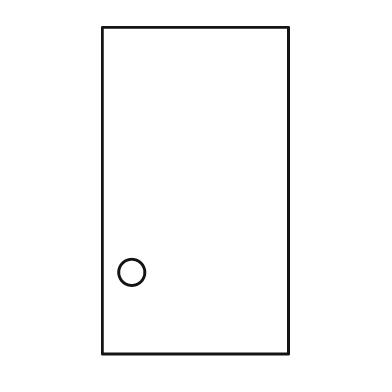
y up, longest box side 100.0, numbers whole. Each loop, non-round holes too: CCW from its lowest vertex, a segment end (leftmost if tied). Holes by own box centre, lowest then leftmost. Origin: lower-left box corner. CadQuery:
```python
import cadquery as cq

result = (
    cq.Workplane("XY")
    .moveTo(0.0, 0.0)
    .lineTo(57.0, 0.0)
    .lineTo(57.0, 100.0)
    .lineTo(0.0, 100.0)
    .close()
    .moveTo(9.0, 25.0)
    .circle(4.0)
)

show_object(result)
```